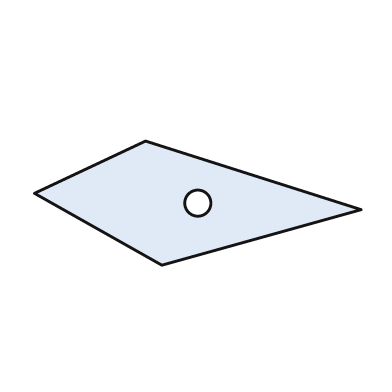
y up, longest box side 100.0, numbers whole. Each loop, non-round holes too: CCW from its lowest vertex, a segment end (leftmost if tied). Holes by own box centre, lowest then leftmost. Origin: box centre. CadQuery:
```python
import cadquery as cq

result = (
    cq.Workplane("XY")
    .moveTo(-11.0, -19.0)
    .lineTo(50.0, -2.0)
    .lineTo(-16.0, 19.0)
    .lineTo(-50.0, 3.0)
    .close()
    .moveTo(0.0, 0.0)
    .circle(4.0)
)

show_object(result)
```